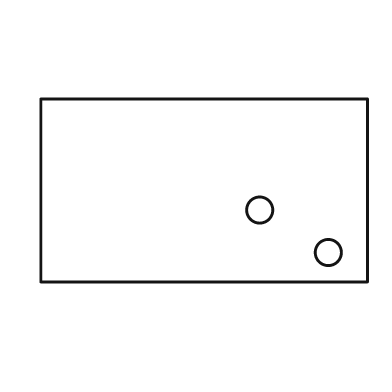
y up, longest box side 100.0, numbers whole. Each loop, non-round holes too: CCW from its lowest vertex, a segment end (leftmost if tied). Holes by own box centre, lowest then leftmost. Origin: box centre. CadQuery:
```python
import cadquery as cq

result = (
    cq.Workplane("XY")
    .moveTo(-50.0, -28.0)
    .lineTo(50.0, -28.0)
    .lineTo(50.0, 28.0)
    .lineTo(-50.0, 28.0)
    .close()
    .moveTo(38.0, -19.0)
    .circle(4.0)
    .moveTo(17.0, -6.0)
    .circle(4.0)
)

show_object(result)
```